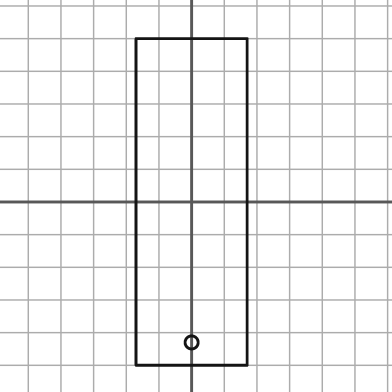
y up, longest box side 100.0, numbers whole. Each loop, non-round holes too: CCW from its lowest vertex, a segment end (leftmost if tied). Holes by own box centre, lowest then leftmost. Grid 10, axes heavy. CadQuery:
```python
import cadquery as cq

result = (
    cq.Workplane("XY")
    .moveTo(-17.0, -50.0)
    .lineTo(17.0, -50.0)
    .lineTo(17.0, 50.0)
    .lineTo(-17.0, 50.0)
    .close()
    .moveTo(0.0, -43.0)
    .circle(2.0)
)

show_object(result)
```